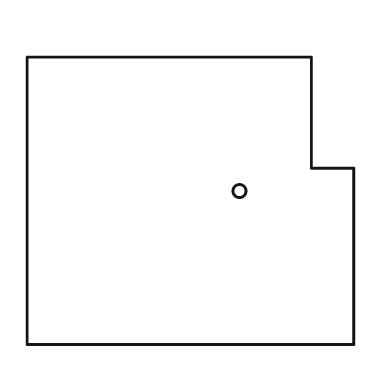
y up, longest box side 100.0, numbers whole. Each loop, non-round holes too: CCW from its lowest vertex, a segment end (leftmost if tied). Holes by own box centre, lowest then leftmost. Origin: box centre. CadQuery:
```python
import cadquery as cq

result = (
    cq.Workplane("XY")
    .moveTo(-50.0, -44.0)
    .lineTo(50.0, -44.0)
    .lineTo(50.0, 10.0)
    .lineTo(37.0, 10.0)
    .lineTo(37.0, 44.0)
    .lineTo(-50.0, 44.0)
    .close()
    .moveTo(15.0, 3.0)
    .circle(2.0)
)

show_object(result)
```